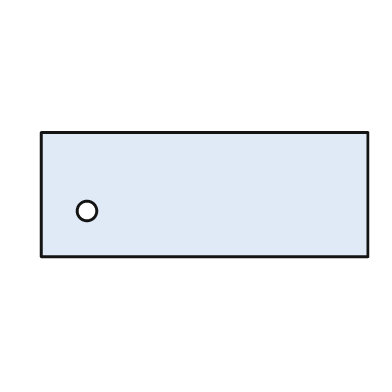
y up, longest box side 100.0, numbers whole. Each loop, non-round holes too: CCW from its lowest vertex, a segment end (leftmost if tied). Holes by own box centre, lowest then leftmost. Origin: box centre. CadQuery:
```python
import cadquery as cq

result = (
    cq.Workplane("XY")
    .moveTo(-50.0, -19.0)
    .lineTo(50.0, -19.0)
    .lineTo(50.0, 19.0)
    .lineTo(-50.0, 19.0)
    .close()
    .moveTo(-36.0, -5.0)
    .circle(3.0)
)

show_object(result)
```